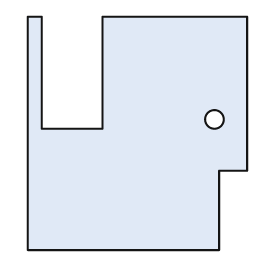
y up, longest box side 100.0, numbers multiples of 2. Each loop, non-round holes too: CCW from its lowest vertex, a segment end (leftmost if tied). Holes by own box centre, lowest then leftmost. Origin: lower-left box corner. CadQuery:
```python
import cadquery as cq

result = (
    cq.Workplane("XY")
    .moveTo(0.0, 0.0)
    .lineTo(82.0, 0.0)
    .lineTo(82.0, 34.0)
    .lineTo(94.0, 34.0)
    .lineTo(94.0, 100.0)
    .lineTo(32.0, 100.0)
    .lineTo(32.0, 52.0)
    .lineTo(6.0, 52.0)
    .lineTo(6.0, 100.0)
    .lineTo(0.0, 100.0)
    .close()
    .moveTo(80.0, 56.0)
    .circle(4.0)
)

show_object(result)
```